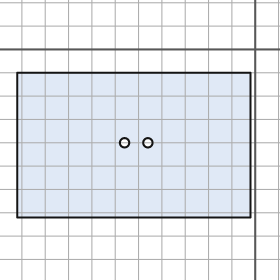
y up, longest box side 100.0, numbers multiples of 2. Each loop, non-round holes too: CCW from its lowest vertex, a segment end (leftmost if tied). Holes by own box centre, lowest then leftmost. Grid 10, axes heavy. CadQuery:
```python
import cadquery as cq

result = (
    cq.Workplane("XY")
    .moveTo(-102.0, -72.0)
    .lineTo(-2.0, -72.0)
    .lineTo(-2.0, -10.0)
    .lineTo(-102.0, -10.0)
    .close()
    .moveTo(-56.0, -40.0)
    .circle(2.0)
    .moveTo(-46.0, -40.0)
    .circle(2.0)
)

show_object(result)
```